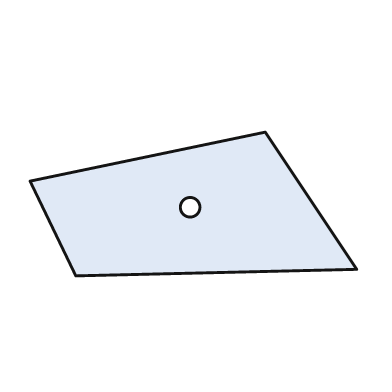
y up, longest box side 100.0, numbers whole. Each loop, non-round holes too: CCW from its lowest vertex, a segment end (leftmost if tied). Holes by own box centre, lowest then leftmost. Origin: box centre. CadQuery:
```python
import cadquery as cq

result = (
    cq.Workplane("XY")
    .moveTo(-36.0, -22.0)
    .lineTo(50.0, -20.0)
    .lineTo(22.0, 22.0)
    .lineTo(-50.0, 7.0)
    .close()
    .moveTo(-1.0, -1.0)
    .circle(3.0)
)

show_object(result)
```